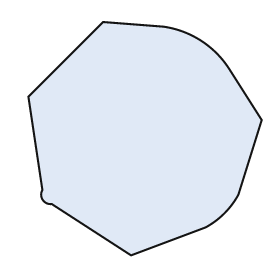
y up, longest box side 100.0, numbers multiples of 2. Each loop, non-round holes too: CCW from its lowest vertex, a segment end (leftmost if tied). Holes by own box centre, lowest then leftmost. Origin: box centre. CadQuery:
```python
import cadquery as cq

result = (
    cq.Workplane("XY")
    .moveTo(-6.0, -50.0)
    .lineTo(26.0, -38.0)
    .threePointArc((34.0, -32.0), (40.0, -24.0))
    .lineTo(50.0, 8.0)
    .lineTo(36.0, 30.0)
    .threePointArc((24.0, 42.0), (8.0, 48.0))
    .lineTo(-18.0, 50.0)
    .lineTo(-50.0, 18.0)
    .lineTo(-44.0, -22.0)
    .threePointArc((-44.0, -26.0), (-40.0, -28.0))
    .close()
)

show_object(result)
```